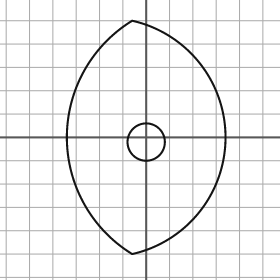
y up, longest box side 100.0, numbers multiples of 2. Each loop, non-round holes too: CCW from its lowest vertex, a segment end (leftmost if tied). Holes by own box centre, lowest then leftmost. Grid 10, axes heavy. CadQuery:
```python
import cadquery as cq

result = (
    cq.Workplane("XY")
    .moveTo(-6.0, -50.0)
    .threePointArc((34.0, 0.0), (-6.0, 50.0))
    .threePointArc((-34.0, 0.0), (-6.0, -50.0))
    .close()
    .moveTo(0.0, -2.0)
    .circle(8.0)
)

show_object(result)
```